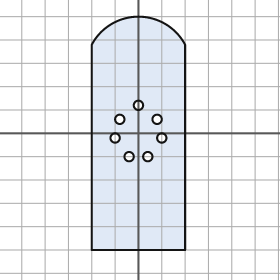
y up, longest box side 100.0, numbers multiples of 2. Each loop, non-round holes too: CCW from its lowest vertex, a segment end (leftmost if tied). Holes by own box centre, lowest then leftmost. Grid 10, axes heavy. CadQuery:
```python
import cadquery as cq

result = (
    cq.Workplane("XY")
    .moveTo(-20.0, -50.0)
    .lineTo(20.0, -50.0)
    .lineTo(20.0, 38.0)
    .threePointArc((0.0, 50.0), (-20.0, 38.0))
    .close()
    .moveTo(-4.0, -10.0)
    .circle(2.0)
    .moveTo(4.0, -10.0)
    .circle(2.0)
    .moveTo(-10.0, -2.0)
    .circle(2.0)
    .moveTo(10.0, -2.0)
    .circle(2.0)
    .moveTo(-8.0, 6.0)
    .circle(2.0)
    .moveTo(8.0, 6.0)
    .circle(2.0)
    .moveTo(0.0, 12.0)
    .circle(2.0)
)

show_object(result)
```